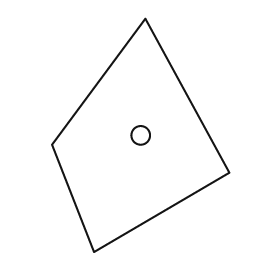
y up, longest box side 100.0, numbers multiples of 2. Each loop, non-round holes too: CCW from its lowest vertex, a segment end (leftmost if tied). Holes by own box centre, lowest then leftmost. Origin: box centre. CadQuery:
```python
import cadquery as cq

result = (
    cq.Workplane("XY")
    .moveTo(-20.0, -50.0)
    .lineTo(38.0, -16.0)
    .lineTo(2.0, 50.0)
    .lineTo(-38.0, -4.0)
    .close()
    .moveTo(0.0, 0.0)
    .circle(4.0)
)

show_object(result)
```